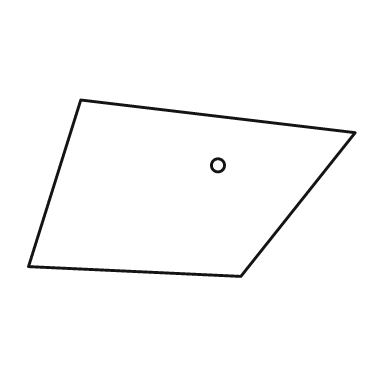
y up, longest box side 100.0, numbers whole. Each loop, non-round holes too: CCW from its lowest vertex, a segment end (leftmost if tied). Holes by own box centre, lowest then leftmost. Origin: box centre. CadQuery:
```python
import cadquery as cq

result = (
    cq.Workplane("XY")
    .moveTo(15.0, -27.0)
    .lineTo(50.0, 17.0)
    .lineTo(-34.0, 27.0)
    .lineTo(-50.0, -24.0)
    .close()
    .moveTo(8.0, 7.0)
    .circle(2.0)
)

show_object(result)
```